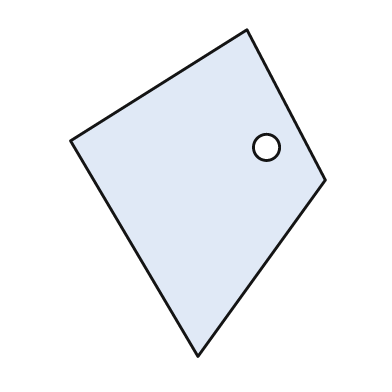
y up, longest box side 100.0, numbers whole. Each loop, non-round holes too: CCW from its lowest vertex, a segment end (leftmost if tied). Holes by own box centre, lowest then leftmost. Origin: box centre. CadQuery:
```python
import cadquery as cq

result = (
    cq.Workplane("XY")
    .moveTo(0.0, -50.0)
    .lineTo(39.0, 4.0)
    .lineTo(15.0, 50.0)
    .lineTo(-39.0, 16.0)
    .close()
    .moveTo(21.0, 14.0)
    .circle(4.0)
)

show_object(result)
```